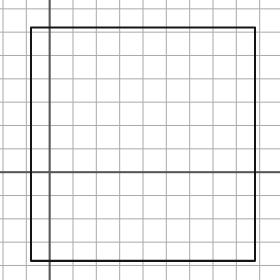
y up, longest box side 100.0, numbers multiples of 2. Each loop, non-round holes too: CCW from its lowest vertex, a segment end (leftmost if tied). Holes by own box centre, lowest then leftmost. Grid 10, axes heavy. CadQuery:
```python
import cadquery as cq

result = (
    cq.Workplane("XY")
    .moveTo(-8.0, -38.0)
    .lineTo(88.0, -38.0)
    .lineTo(88.0, 62.0)
    .lineTo(-8.0, 62.0)
    .close()
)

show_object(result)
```